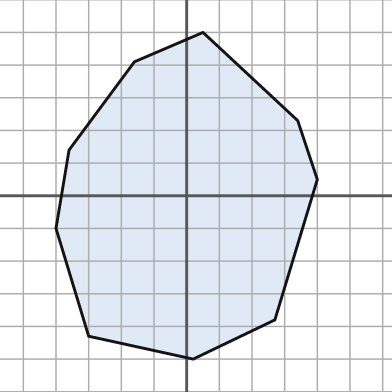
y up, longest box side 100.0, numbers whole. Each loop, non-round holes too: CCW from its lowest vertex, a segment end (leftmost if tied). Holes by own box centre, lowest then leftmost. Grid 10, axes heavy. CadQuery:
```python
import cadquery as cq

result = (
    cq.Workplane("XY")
    .moveTo(2.0, -50.0)
    .lineTo(27.0, -38.0)
    .lineTo(40.0, 5.0)
    .lineTo(34.0, 23.0)
    .lineTo(5.0, 50.0)
    .lineTo(-16.0, 41.0)
    .lineTo(-36.0, 14.0)
    .lineTo(-40.0, -10.0)
    .lineTo(-30.0, -43.0)
    .close()
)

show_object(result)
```